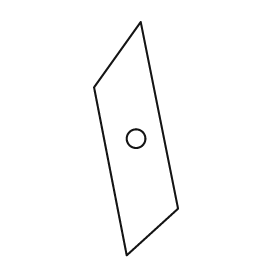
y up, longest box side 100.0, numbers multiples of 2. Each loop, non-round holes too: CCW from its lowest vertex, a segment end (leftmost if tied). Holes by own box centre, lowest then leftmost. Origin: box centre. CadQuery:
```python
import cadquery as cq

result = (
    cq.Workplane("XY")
    .moveTo(-4.0, -50.0)
    .lineTo(18.0, -30.0)
    .lineTo(2.0, 50.0)
    .lineTo(-18.0, 22.0)
    .close()
    .moveTo(0.0, 0.0)
    .circle(4.0)
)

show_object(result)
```